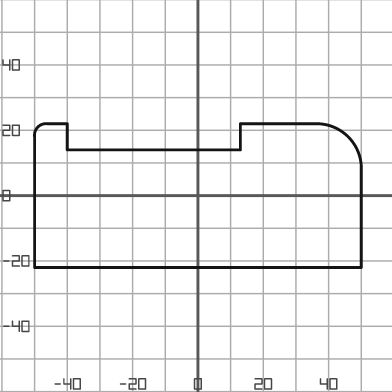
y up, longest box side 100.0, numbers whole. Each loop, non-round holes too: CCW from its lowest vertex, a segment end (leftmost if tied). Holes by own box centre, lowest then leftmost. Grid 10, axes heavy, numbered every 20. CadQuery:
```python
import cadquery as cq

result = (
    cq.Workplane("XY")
    .moveTo(-50.0, -22.0)
    .lineTo(50.0, -22.0)
    .lineTo(50.0, 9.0)
    .threePointArc((46.0, 18.0), (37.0, 22.0))
    .lineTo(13.0, 22.0)
    .lineTo(13.0, 14.0)
    .lineTo(-40.0, 14.0)
    .lineTo(-40.0, 22.0)
    .lineTo(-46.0, 22.0)
    .threePointArc((-49.0, 21.0), (-50.0, 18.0))
    .close()
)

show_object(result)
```